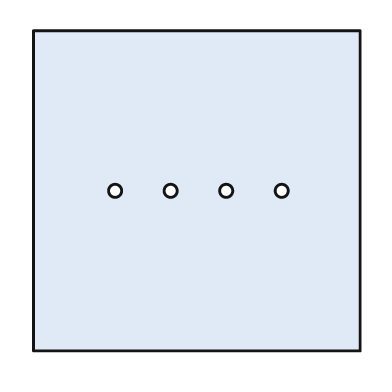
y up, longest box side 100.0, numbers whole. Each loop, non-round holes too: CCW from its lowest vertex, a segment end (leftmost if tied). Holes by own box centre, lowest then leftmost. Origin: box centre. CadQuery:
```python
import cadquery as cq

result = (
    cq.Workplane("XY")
    .moveTo(-50.0, -49.0)
    .lineTo(50.0, -49.0)
    .lineTo(50.0, 49.0)
    .lineTo(-50.0, 49.0)
    .close()
    .moveTo(-25.0, 0.0)
    .circle(2.0)
    .moveTo(-8.0, 0.0)
    .circle(2.0)
    .moveTo(9.0, 0.0)
    .circle(2.0)
    .moveTo(26.0, 0.0)
    .circle(2.0)
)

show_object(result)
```